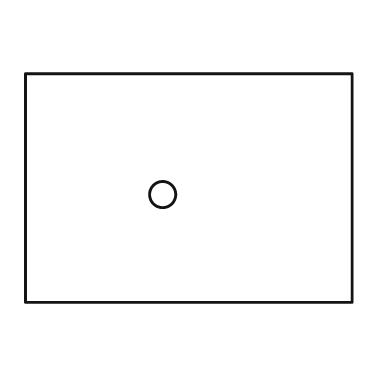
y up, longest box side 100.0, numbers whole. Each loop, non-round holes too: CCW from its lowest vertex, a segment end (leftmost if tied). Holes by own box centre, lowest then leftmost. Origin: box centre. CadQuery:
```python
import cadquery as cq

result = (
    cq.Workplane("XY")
    .moveTo(-50.0, -35.0)
    .lineTo(50.0, -35.0)
    .lineTo(50.0, 35.0)
    .lineTo(-50.0, 35.0)
    .close()
    .moveTo(-8.0, -2.0)
    .circle(4.0)
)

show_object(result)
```